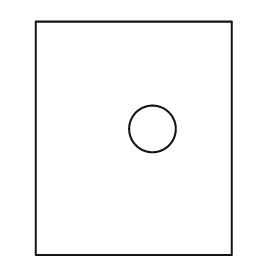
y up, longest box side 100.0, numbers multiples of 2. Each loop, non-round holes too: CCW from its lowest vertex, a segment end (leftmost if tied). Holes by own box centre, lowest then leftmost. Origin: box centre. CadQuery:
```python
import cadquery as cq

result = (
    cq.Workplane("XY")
    .moveTo(-42.0, -50.0)
    .lineTo(42.0, -50.0)
    .lineTo(42.0, 50.0)
    .lineTo(-42.0, 50.0)
    .close()
    .moveTo(8.0, 4.0)
    .circle(10.0)
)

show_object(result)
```